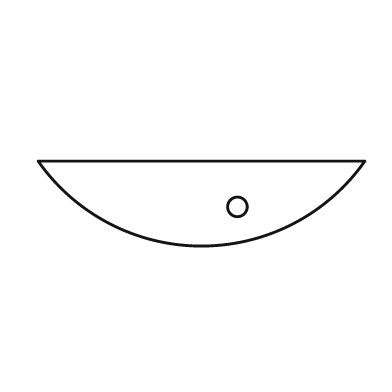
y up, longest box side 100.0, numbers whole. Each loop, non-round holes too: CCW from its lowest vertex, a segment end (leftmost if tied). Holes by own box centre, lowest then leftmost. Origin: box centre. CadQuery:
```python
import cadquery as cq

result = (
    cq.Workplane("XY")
    .moveTo(-50.0, 13.0)
    .threePointArc((0.0, -13.0), (50.0, 13.0))
    .close()
    .moveTo(11.0, -1.0)
    .circle(3.0)
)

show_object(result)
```